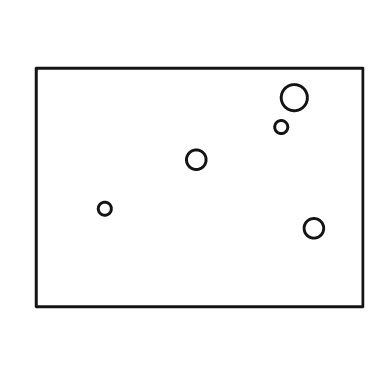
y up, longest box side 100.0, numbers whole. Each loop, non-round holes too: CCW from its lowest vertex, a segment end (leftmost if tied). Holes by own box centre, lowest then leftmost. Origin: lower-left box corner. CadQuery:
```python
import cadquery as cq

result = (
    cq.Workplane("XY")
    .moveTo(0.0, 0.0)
    .lineTo(100.0, 0.0)
    .lineTo(100.0, 73.0)
    .lineTo(0.0, 73.0)
    .close()
    .moveTo(85.0, 24.0)
    .circle(3.0)
    .moveTo(21.0, 30.0)
    .circle(2.0)
    .moveTo(49.0, 45.0)
    .circle(3.0)
    .moveTo(75.0, 55.0)
    .circle(2.0)
    .moveTo(79.0, 64.0)
    .circle(4.0)
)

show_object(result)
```